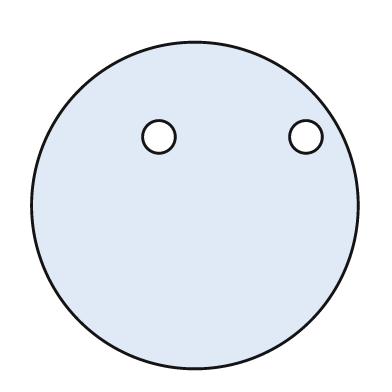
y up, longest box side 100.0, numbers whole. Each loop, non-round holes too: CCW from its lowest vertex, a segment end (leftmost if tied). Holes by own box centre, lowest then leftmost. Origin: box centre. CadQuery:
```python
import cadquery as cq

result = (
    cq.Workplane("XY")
    .moveTo(0.0, 0.0)
    .circle(50.0)
    .moveTo(-11.0, 21.0)
    .circle(5.0)
    .moveTo(34.0, 21.0)
    .circle(5.0)
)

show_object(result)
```